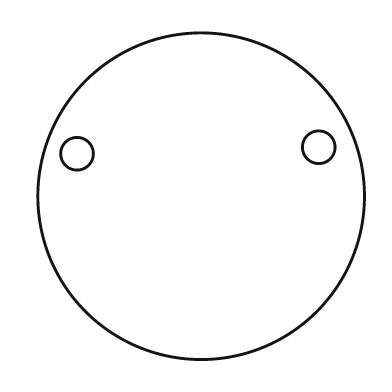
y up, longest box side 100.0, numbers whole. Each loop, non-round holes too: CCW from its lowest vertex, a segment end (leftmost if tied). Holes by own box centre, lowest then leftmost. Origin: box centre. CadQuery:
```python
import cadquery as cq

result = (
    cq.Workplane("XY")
    .moveTo(0.0, 0.0)
    .circle(50.0)
    .moveTo(-38.0, 13.0)
    .circle(5.0)
    .moveTo(36.0, 15.0)
    .circle(5.0)
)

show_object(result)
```